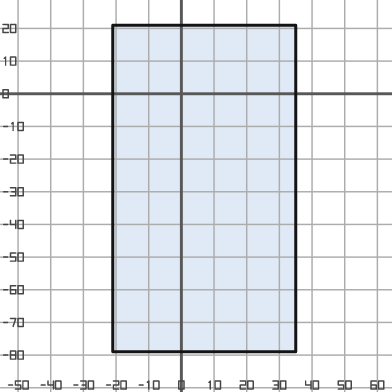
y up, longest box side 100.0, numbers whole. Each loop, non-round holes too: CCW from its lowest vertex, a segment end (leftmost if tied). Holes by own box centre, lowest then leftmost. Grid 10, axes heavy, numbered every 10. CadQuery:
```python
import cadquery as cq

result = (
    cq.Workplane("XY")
    .moveTo(-21.0, -79.0)
    .lineTo(35.0, -79.0)
    .lineTo(35.0, 21.0)
    .lineTo(-21.0, 21.0)
    .close()
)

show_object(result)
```